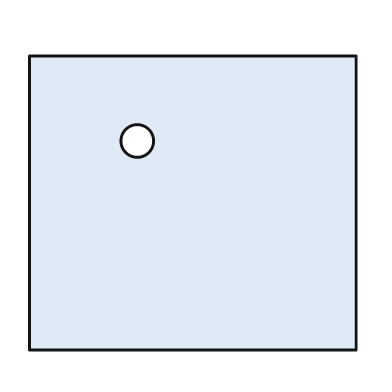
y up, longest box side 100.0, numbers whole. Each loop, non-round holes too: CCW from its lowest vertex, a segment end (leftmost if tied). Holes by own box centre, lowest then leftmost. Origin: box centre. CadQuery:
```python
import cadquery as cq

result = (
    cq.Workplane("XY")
    .moveTo(-50.0, -45.0)
    .lineTo(50.0, -45.0)
    .lineTo(50.0, 45.0)
    .lineTo(-50.0, 45.0)
    .close()
    .moveTo(-17.0, 19.0)
    .circle(5.0)
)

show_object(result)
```